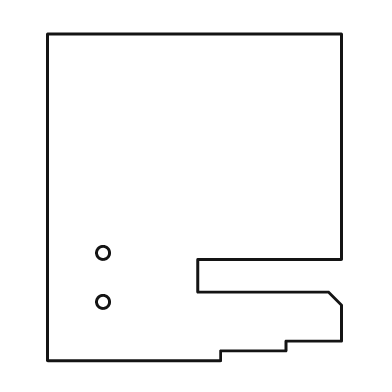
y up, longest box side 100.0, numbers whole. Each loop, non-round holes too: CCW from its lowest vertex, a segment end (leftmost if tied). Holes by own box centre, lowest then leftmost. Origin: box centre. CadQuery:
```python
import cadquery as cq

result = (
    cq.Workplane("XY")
    .moveTo(-45.0, -50.0)
    .lineTo(8.0, -50.0)
    .lineTo(8.0, -47.0)
    .lineTo(28.0, -47.0)
    .lineTo(28.0, -44.0)
    .lineTo(45.0, -44.0)
    .lineTo(45.0, -33.0)
    .lineTo(41.0, -29.0)
    .lineTo(1.0, -29.0)
    .lineTo(1.0, -19.0)
    .lineTo(45.0, -19.0)
    .lineTo(45.0, 50.0)
    .lineTo(-45.0, 50.0)
    .close()
    .moveTo(-28.0, -32.0)
    .circle(2.0)
    .moveTo(-28.0, -17.0)
    .circle(2.0)
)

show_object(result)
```